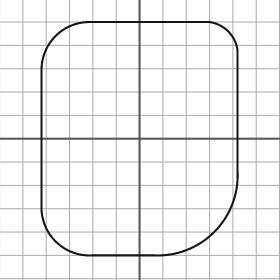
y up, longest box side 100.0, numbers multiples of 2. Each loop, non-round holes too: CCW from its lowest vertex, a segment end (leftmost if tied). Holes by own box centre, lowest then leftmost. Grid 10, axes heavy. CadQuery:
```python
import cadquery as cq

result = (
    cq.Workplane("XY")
    .moveTo(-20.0, -50.0)
    .lineTo(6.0, -50.0)
    .threePointArc((32.0, -40.0), (42.0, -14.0))
    .lineTo(42.0, 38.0)
    .threePointArc((38.0, 46.0), (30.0, 50.0))
    .lineTo(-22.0, 50.0)
    .threePointArc((-36.0, 44.0), (-42.0, 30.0))
    .lineTo(-42.0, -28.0)
    .threePointArc((-36.0, -44.0), (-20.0, -50.0))
    .close()
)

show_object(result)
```